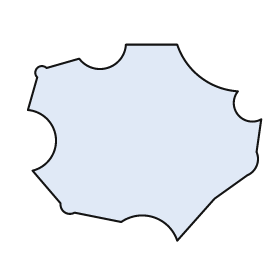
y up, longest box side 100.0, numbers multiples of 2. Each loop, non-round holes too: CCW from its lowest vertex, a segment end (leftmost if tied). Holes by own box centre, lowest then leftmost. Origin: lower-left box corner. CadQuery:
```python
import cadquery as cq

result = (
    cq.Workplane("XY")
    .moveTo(64.0, 0.0)
    .lineTo(80.0, 18.0)
    .lineTo(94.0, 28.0)
    .threePointArc((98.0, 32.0), (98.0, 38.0))
    .lineTo(100.0, 52.0)
    .threePointArc((90.0, 54.0), (90.0, 64.0))
    .threePointArc((74.0, 70.0), (64.0, 84.0))
    .lineTo(42.0, 84.0)
    .threePointArc((34.0, 74.0), (22.0, 78.0))
    .lineTo(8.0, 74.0)
    .threePointArc((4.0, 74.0), (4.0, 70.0))
    .lineTo(0.0, 56.0)
    .threePointArc((12.0, 44.0), (2.0, 30.0))
    .lineTo(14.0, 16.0)
    .threePointArc((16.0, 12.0), (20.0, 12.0))
    .lineTo(40.0, 8.0)
    .threePointArc((54.0, 10.0), (64.0, 0.0))
    .close()
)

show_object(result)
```